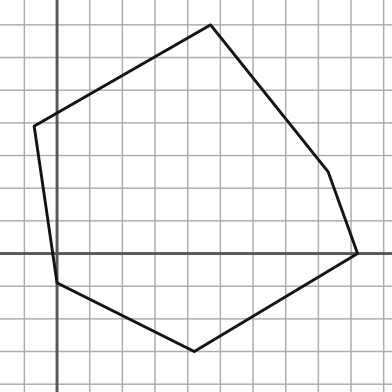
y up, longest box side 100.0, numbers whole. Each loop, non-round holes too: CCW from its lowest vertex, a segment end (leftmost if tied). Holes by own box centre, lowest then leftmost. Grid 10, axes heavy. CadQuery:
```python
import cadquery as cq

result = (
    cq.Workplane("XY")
    .moveTo(42.0, -30.0)
    .lineTo(92.0, 0.0)
    .lineTo(83.0, 25.0)
    .lineTo(47.0, 70.0)
    .lineTo(-7.0, 39.0)
    .lineTo(0.0, -9.0)
    .close()
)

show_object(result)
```